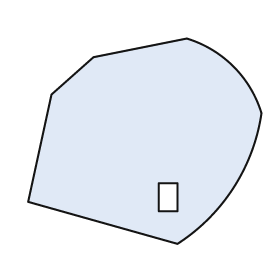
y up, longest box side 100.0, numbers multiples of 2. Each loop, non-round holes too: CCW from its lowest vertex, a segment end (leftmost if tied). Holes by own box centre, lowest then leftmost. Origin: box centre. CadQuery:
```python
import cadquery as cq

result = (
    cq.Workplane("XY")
    .moveTo(14.0, -44.0)
    .threePointArc((38.0, -20.0), (50.0, 12.0))
    .threePointArc((38.0, 32.0), (18.0, 44.0))
    .lineTo(-22.0, 36.0)
    .lineTo(-40.0, 20.0)
    .lineTo(-50.0, -26.0)
    .close()
    .moveTo(6.0, -30.0)
    .lineTo(14.0, -30.0)
    .lineTo(14.0, -18.0)
    .lineTo(6.0, -18.0)
    .close()
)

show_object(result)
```